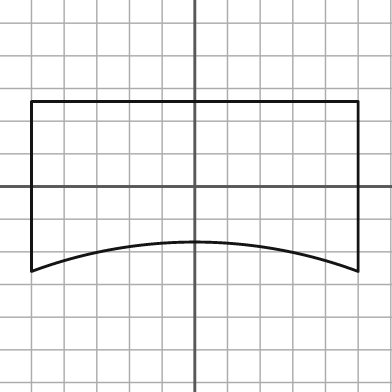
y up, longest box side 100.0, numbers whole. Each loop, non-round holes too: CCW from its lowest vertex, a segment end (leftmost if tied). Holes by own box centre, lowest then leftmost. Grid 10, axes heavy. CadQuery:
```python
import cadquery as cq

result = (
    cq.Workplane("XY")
    .moveTo(-50.0, -26.0)
    .threePointArc((0.0, -17.0), (50.0, -26.0))
    .lineTo(50.0, 26.0)
    .lineTo(-50.0, 26.0)
    .close()
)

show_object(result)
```